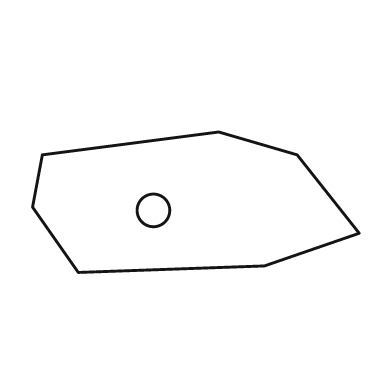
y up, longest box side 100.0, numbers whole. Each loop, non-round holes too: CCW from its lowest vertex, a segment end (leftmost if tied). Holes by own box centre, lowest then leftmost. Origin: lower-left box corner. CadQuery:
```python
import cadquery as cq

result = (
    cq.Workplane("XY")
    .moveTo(14.0, 0.0)
    .lineTo(71.0, 2.0)
    .lineTo(100.0, 12.0)
    .lineTo(81.0, 36.0)
    .lineTo(57.0, 43.0)
    .lineTo(3.0, 36.0)
    .lineTo(0.0, 20.0)
    .close()
    .moveTo(37.0, 19.0)
    .circle(5.0)
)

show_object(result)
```